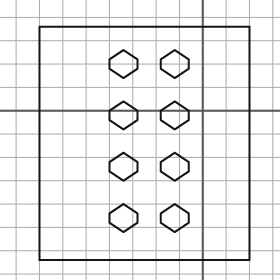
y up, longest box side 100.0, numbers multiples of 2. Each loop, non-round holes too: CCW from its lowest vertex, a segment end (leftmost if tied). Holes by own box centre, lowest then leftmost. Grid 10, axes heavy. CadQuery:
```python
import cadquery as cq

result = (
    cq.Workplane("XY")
    .moveTo(-70.0, -64.0)
    .lineTo(20.0, -64.0)
    .lineTo(20.0, 36.0)
    .lineTo(-70.0, 36.0)
    .close()
    .moveTo(-34.0, -52.0)
    .lineTo(-28.0, -48.0)
    .lineTo(-28.0, -44.0)
    .lineTo(-34.0, -40.0)
    .lineTo(-40.0, -44.0)
    .lineTo(-40.0, -48.0)
    .close()
    .moveTo(-12.0, -52.0)
    .lineTo(-6.0, -48.0)
    .lineTo(-6.0, -44.0)
    .lineTo(-12.0, -40.0)
    .lineTo(-18.0, -44.0)
    .lineTo(-18.0, -48.0)
    .close()
    .moveTo(-34.0, -30.0)
    .lineTo(-28.0, -26.0)
    .lineTo(-28.0, -22.0)
    .lineTo(-34.0, -18.0)
    .lineTo(-40.0, -22.0)
    .lineTo(-40.0, -26.0)
    .close()
    .moveTo(-12.0, -30.0)
    .lineTo(-6.0, -26.0)
    .lineTo(-6.0, -22.0)
    .lineTo(-12.0, -18.0)
    .lineTo(-18.0, -22.0)
    .lineTo(-18.0, -26.0)
    .close()
    .moveTo(-34.0, -8.0)
    .lineTo(-28.0, -4.0)
    .lineTo(-28.0, 0.0)
    .lineTo(-34.0, 4.0)
    .lineTo(-40.0, 0.0)
    .lineTo(-40.0, -4.0)
    .close()
    .moveTo(-12.0, -8.0)
    .lineTo(-6.0, -4.0)
    .lineTo(-6.0, 0.0)
    .lineTo(-12.0, 4.0)
    .lineTo(-18.0, 0.0)
    .lineTo(-18.0, -4.0)
    .close()
    .moveTo(-34.0, 14.0)
    .lineTo(-28.0, 18.0)
    .lineTo(-28.0, 22.0)
    .lineTo(-34.0, 26.0)
    .lineTo(-40.0, 22.0)
    .lineTo(-40.0, 18.0)
    .close()
    .moveTo(-12.0, 14.0)
    .lineTo(-6.0, 18.0)
    .lineTo(-6.0, 22.0)
    .lineTo(-12.0, 26.0)
    .lineTo(-18.0, 22.0)
    .lineTo(-18.0, 18.0)
    .close()
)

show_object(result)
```